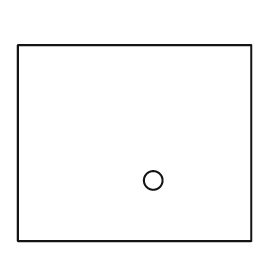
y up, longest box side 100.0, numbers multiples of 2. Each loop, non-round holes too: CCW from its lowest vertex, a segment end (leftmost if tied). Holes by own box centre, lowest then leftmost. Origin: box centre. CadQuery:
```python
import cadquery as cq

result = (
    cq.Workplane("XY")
    .moveTo(-50.0, -42.0)
    .lineTo(50.0, -42.0)
    .lineTo(50.0, 42.0)
    .lineTo(-50.0, 42.0)
    .close()
    .moveTo(8.0, -16.0)
    .circle(4.0)
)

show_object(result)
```